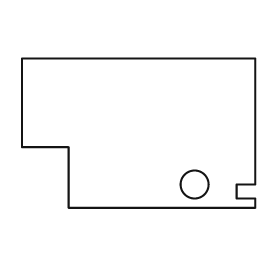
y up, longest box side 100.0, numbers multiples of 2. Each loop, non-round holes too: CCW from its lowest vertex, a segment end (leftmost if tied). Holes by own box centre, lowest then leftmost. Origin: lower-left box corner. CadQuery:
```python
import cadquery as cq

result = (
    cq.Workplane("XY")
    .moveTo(20.0, 0.0)
    .lineTo(100.0, 0.0)
    .lineTo(100.0, 4.0)
    .lineTo(92.0, 4.0)
    .lineTo(92.0, 10.0)
    .lineTo(100.0, 10.0)
    .lineTo(100.0, 64.0)
    .lineTo(0.0, 64.0)
    .lineTo(0.0, 26.0)
    .lineTo(20.0, 26.0)
    .close()
    .moveTo(74.0, 10.0)
    .circle(6.0)
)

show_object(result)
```